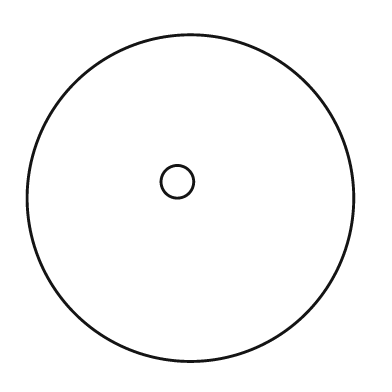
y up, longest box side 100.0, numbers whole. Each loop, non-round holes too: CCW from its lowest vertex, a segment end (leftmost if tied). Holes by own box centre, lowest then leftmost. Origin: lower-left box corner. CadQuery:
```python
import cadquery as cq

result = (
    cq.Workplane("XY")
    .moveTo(50.0, 50.0)
    .circle(50.0)
    .moveTo(46.0, 55.0)
    .circle(5.0)
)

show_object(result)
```